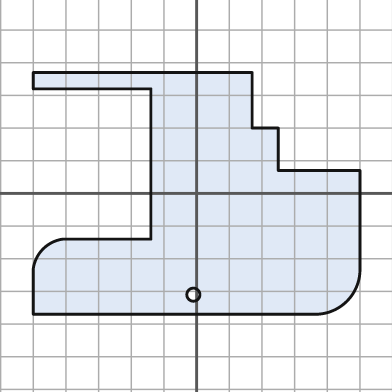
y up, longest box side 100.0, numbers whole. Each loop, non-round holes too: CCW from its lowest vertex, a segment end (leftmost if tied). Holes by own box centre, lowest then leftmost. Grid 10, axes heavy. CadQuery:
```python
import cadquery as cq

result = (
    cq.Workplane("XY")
    .moveTo(-50.0, -37.0)
    .lineTo(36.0, -37.0)
    .threePointArc((46.0, -33.0), (50.0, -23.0))
    .lineTo(50.0, 7.0)
    .lineTo(25.0, 7.0)
    .lineTo(25.0, 20.0)
    .lineTo(17.0, 20.0)
    .lineTo(17.0, 37.0)
    .lineTo(-50.0, 37.0)
    .lineTo(-50.0, 32.0)
    .lineTo(-14.0, 32.0)
    .lineTo(-14.0, -14.0)
    .lineTo(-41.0, -14.0)
    .threePointArc((-47.0, -17.0), (-50.0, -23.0))
    .close()
    .moveTo(-1.0, -31.0)
    .circle(2.0)
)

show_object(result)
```